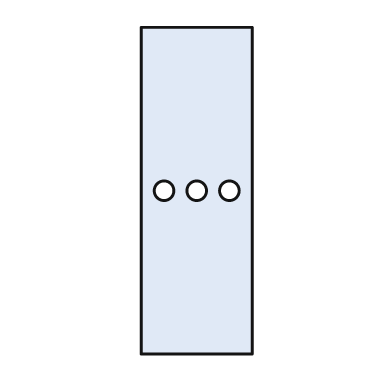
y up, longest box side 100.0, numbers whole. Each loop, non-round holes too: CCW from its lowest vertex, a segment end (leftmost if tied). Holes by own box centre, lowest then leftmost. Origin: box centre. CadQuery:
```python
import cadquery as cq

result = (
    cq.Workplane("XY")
    .moveTo(-17.0, -50.0)
    .lineTo(17.0, -50.0)
    .lineTo(17.0, 50.0)
    .lineTo(-17.0, 50.0)
    .close()
    .moveTo(-10.0, 0.0)
    .circle(3.0)
    .moveTo(0.0, 0.0)
    .circle(3.0)
    .moveTo(10.0, 0.0)
    .circle(3.0)
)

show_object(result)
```